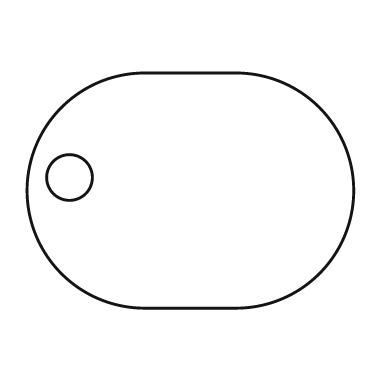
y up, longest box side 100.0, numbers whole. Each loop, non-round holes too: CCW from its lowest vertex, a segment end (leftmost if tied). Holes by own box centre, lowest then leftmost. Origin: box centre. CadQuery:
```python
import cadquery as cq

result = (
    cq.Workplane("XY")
    .moveTo(-14.0, -36.0)
    .lineTo(14.0, -36.0)
    .threePointArc((50.0, 0.0), (14.0, 36.0))
    .lineTo(-14.0, 36.0)
    .threePointArc((-50.0, 0.0), (-14.0, -36.0))
    .close()
    .moveTo(-37.0, 4.0)
    .circle(7.0)
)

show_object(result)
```